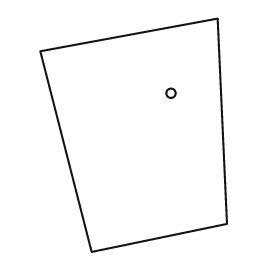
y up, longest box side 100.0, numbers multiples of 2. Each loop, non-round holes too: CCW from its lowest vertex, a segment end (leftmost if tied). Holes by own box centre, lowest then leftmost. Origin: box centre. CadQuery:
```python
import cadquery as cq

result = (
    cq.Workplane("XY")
    .moveTo(-18.0, -50.0)
    .lineTo(40.0, -38.0)
    .lineTo(36.0, 50.0)
    .lineTo(-40.0, 36.0)
    .close()
    .moveTo(16.0, 18.0)
    .circle(2.0)
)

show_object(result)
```